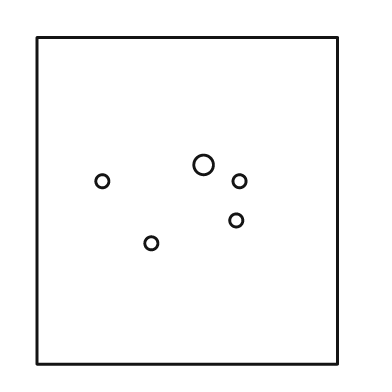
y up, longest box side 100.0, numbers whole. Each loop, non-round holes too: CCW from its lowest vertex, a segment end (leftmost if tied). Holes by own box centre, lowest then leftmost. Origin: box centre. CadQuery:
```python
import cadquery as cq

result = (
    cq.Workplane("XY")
    .moveTo(-46.0, -50.0)
    .lineTo(46.0, -50.0)
    .lineTo(46.0, 50.0)
    .lineTo(-46.0, 50.0)
    .close()
    .moveTo(-11.0, -13.0)
    .circle(2.0)
    .moveTo(15.0, -6.0)
    .circle(2.0)
    .moveTo(-26.0, 6.0)
    .circle(2.0)
    .moveTo(16.0, 6.0)
    .circle(2.0)
    .moveTo(5.0, 11.0)
    .circle(3.0)
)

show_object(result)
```